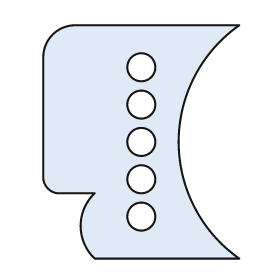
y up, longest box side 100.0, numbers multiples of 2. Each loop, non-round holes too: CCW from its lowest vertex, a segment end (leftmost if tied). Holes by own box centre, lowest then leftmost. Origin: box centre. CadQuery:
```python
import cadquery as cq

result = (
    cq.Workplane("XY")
    .moveTo(-20.0, -50.0)
    .lineTo(42.0, -50.0)
    .threePointArc((16.0, 0.0), (42.0, 50.0))
    .lineTo(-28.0, 50.0)
    .threePointArc((-38.0, 46.0), (-42.0, 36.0))
    .lineTo(-42.0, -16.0)
    .threePointArc((-40.0, -20.0), (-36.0, -22.0))
    .lineTo(-20.0, -22.0)
    .threePointArc((-26.0, -36.0), (-20.0, -50.0))
    .close()
    .moveTo(0.0, -32.0)
    .circle(6.0)
    .moveTo(0.0, -16.0)
    .circle(6.0)
    .moveTo(0.0, 0.0)
    .circle(6.0)
    .moveTo(0.0, 16.0)
    .circle(6.0)
    .moveTo(0.0, 32.0)
    .circle(6.0)
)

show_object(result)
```